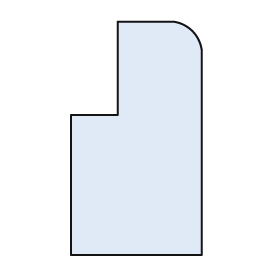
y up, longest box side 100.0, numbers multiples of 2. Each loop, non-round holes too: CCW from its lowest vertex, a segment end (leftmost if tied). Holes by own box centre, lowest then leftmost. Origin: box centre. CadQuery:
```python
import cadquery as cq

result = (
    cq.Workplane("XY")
    .moveTo(-28.0, -50.0)
    .lineTo(28.0, -50.0)
    .lineTo(28.0, 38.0)
    .threePointArc((24.0, 46.0), (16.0, 50.0))
    .lineTo(-8.0, 50.0)
    .lineTo(-8.0, 10.0)
    .lineTo(-28.0, 10.0)
    .close()
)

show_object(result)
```